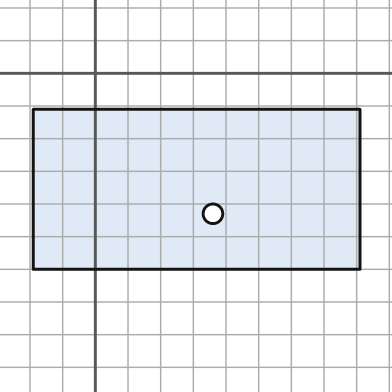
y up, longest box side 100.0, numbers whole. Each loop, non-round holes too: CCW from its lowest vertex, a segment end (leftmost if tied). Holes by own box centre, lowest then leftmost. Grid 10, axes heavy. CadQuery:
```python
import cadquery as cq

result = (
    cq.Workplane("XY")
    .moveTo(-19.0, -60.0)
    .lineTo(81.0, -60.0)
    .lineTo(81.0, -11.0)
    .lineTo(-19.0, -11.0)
    .close()
    .moveTo(36.0, -43.0)
    .circle(3.0)
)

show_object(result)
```